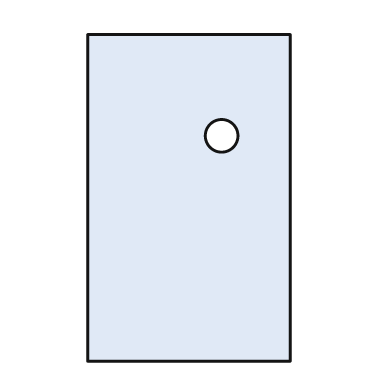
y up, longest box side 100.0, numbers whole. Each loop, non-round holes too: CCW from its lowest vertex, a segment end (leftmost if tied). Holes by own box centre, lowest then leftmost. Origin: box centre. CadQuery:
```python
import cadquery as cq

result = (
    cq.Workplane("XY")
    .moveTo(-31.0, -50.0)
    .lineTo(31.0, -50.0)
    .lineTo(31.0, 50.0)
    .lineTo(-31.0, 50.0)
    .close()
    .moveTo(10.0, 19.0)
    .circle(5.0)
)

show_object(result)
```